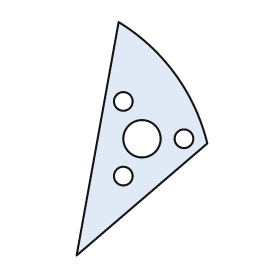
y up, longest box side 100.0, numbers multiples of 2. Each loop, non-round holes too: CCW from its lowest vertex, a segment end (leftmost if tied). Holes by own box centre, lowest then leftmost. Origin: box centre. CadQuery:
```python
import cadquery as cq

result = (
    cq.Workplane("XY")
    .moveTo(-28.0, -50.0)
    .lineTo(28.0, -2.0)
    .threePointArc((14.0, 28.0), (-10.0, 50.0))
    .close()
    .moveTo(-8.0, -16.0)
    .circle(4.0)
    .moveTo(0.0, 0.0)
    .circle(8.0)
    .moveTo(18.0, 0.0)
    .circle(4.0)
    .moveTo(-8.0, 16.0)
    .circle(4.0)
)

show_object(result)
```